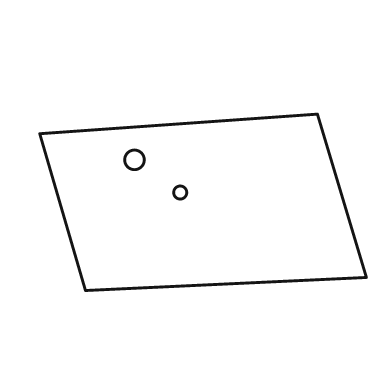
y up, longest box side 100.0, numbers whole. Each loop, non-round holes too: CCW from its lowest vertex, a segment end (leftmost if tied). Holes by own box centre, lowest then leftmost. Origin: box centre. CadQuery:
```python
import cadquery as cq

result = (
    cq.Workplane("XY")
    .moveTo(-36.0, -27.0)
    .lineTo(50.0, -23.0)
    .lineTo(35.0, 27.0)
    .lineTo(-50.0, 21.0)
    .close()
    .moveTo(-7.0, 3.0)
    .circle(2.0)
    .moveTo(-21.0, 13.0)
    .circle(3.0)
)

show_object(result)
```